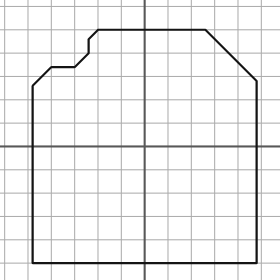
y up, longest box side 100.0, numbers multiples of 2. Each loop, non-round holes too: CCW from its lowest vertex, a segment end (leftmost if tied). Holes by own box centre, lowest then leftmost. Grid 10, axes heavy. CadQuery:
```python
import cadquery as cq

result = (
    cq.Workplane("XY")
    .moveTo(-48.0, -50.0)
    .lineTo(48.0, -50.0)
    .lineTo(48.0, 28.0)
    .lineTo(26.0, 50.0)
    .lineTo(-20.0, 50.0)
    .lineTo(-24.0, 46.0)
    .lineTo(-24.0, 40.0)
    .lineTo(-30.0, 34.0)
    .lineTo(-40.0, 34.0)
    .lineTo(-48.0, 26.0)
    .close()
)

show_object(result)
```